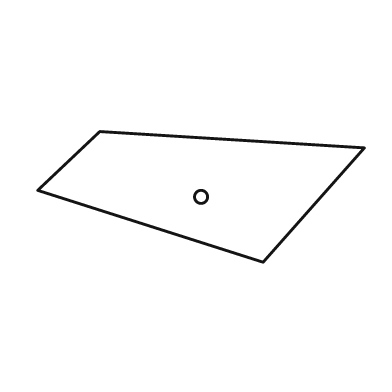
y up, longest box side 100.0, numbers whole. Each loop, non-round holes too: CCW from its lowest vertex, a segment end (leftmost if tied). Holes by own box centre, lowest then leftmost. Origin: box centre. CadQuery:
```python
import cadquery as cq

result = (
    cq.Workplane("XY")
    .moveTo(19.0, -20.0)
    .lineTo(50.0, 15.0)
    .lineTo(-31.0, 20.0)
    .lineTo(-50.0, 2.0)
    .close()
    .moveTo(0.0, 0.0)
    .circle(2.0)
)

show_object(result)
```